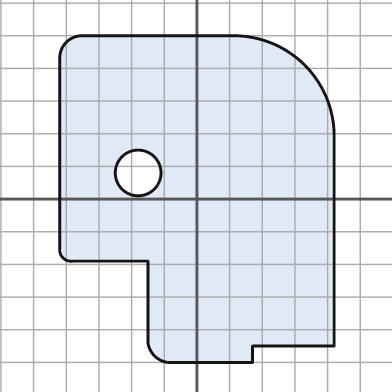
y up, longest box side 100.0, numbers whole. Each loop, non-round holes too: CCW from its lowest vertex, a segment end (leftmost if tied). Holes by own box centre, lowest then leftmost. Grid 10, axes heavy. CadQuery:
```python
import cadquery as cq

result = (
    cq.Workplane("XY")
    .moveTo(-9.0, -50.0)
    .lineTo(17.0, -50.0)
    .lineTo(17.0, -45.0)
    .lineTo(42.0, -45.0)
    .lineTo(42.0, 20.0)
    .threePointArc((33.0, 41.0), (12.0, 50.0))
    .lineTo(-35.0, 50.0)
    .threePointArc((-40.0, 48.0), (-42.0, 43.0))
    .lineTo(-42.0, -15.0)
    .threePointArc((-41.0, -18.0), (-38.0, -19.0))
    .lineTo(-15.0, -19.0)
    .lineTo(-15.0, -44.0)
    .threePointArc((-13.0, -48.0), (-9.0, -50.0))
    .close()
    .moveTo(-18.0, 8.0)
    .circle(7.0)
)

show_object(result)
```